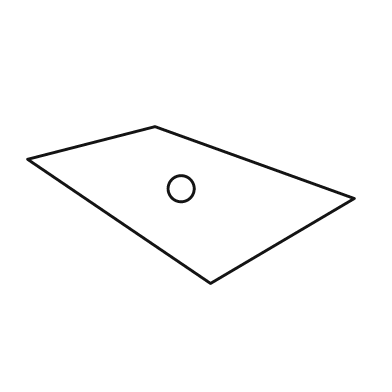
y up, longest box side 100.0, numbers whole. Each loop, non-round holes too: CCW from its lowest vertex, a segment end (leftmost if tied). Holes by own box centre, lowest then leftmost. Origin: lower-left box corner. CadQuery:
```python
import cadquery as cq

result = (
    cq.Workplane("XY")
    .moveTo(56.0, 0.0)
    .lineTo(100.0, 26.0)
    .lineTo(39.0, 48.0)
    .lineTo(0.0, 38.0)
    .close()
    .moveTo(47.0, 29.0)
    .circle(4.0)
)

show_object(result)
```